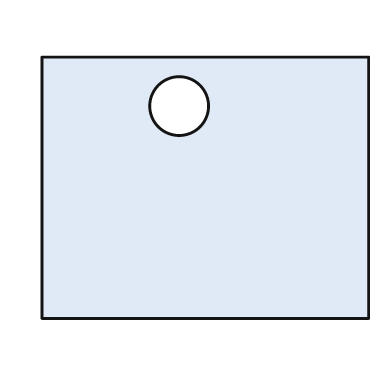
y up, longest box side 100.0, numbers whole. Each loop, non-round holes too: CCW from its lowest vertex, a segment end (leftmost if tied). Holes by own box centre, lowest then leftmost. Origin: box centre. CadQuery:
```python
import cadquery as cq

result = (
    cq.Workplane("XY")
    .moveTo(-50.0, -40.0)
    .lineTo(50.0, -40.0)
    .lineTo(50.0, 40.0)
    .lineTo(-50.0, 40.0)
    .close()
    .moveTo(-8.0, 25.0)
    .circle(9.0)
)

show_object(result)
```